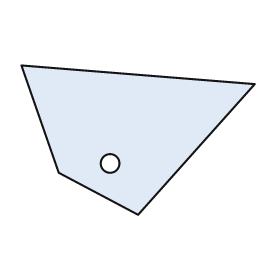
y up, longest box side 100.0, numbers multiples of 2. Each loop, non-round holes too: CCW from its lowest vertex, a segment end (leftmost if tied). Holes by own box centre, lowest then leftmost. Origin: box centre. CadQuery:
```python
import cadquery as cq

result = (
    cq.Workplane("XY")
    .moveTo(0.0, -32.0)
    .lineTo(50.0, 24.0)
    .lineTo(-50.0, 32.0)
    .lineTo(-34.0, -14.0)
    .close()
    .moveTo(-12.0, -10.0)
    .circle(4.0)
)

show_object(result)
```